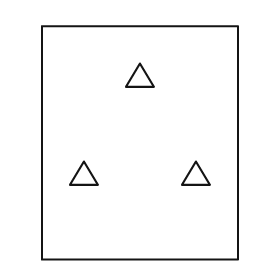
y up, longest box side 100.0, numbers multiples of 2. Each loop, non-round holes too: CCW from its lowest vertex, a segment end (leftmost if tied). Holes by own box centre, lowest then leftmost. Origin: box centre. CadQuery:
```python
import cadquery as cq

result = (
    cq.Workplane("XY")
    .moveTo(-42.0, -50.0)
    .lineTo(42.0, -50.0)
    .lineTo(42.0, 50.0)
    .lineTo(-42.0, 50.0)
    .close()
    .moveTo(-30.0, -18.0)
    .lineTo(-18.0, -18.0)
    .lineTo(-24.0, -8.0)
    .close()
    .moveTo(18.0, -18.0)
    .lineTo(30.0, -18.0)
    .lineTo(24.0, -8.0)
    .close()
    .moveTo(-6.0, 24.0)
    .lineTo(6.0, 24.0)
    .lineTo(0.0, 34.0)
    .close()
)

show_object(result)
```